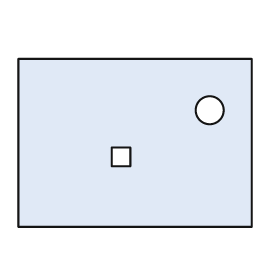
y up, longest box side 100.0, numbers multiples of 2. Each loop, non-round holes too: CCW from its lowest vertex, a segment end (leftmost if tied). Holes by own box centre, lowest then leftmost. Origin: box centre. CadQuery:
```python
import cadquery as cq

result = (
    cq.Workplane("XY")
    .moveTo(-50.0, -36.0)
    .lineTo(50.0, -36.0)
    .lineTo(50.0, 36.0)
    .lineTo(-50.0, 36.0)
    .close()
    .moveTo(-10.0, -10.0)
    .lineTo(-2.0, -10.0)
    .lineTo(-2.0, -2.0)
    .lineTo(-10.0, -2.0)
    .close()
    .moveTo(32.0, 14.0)
    .circle(6.0)
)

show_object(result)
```